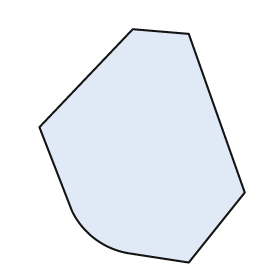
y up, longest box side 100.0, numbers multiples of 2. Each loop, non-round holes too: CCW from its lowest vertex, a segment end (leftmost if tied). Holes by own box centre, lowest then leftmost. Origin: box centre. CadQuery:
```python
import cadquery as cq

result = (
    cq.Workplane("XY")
    .moveTo(20.0, -50.0)
    .lineTo(44.0, -20.0)
    .lineTo(20.0, 48.0)
    .lineTo(-4.0, 50.0)
    .lineTo(-44.0, 8.0)
    .lineTo(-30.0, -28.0)
    .threePointArc((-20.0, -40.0), (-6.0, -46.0))
    .close()
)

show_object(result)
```